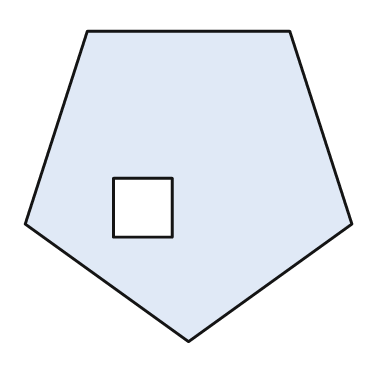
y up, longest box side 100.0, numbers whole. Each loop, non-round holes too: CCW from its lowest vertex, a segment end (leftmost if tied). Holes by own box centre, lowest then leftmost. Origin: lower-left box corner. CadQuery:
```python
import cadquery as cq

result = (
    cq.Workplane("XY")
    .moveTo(50.0, 0.0)
    .lineTo(100.0, 36.0)
    .lineTo(81.0, 95.0)
    .lineTo(19.0, 95.0)
    .lineTo(0.0, 36.0)
    .close()
    .moveTo(27.0, 32.0)
    .lineTo(45.0, 32.0)
    .lineTo(45.0, 50.0)
    .lineTo(27.0, 50.0)
    .close()
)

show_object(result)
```